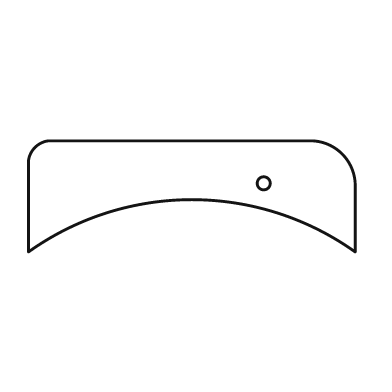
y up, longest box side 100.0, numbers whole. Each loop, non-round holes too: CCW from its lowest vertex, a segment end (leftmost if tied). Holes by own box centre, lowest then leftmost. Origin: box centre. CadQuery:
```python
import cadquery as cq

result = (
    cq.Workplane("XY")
    .moveTo(-50.0, -17.0)
    .threePointArc((0.0, -1.0), (50.0, -17.0))
    .lineTo(50.0, 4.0)
    .threePointArc((46.0, 13.0), (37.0, 17.0))
    .lineTo(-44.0, 17.0)
    .threePointArc((-48.0, 15.0), (-50.0, 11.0))
    .close()
    .moveTo(22.0, 4.0)
    .circle(2.0)
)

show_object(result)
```